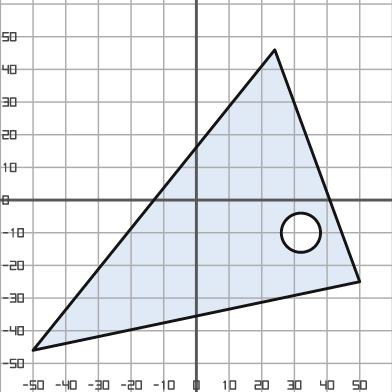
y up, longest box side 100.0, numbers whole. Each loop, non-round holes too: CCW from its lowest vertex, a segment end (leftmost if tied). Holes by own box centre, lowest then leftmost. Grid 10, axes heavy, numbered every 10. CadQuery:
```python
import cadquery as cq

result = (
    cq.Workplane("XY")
    .moveTo(-50.0, -46.0)
    .lineTo(50.0, -25.0)
    .lineTo(24.0, 46.0)
    .close()
    .moveTo(32.0, -10.0)
    .circle(6.0)
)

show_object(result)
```